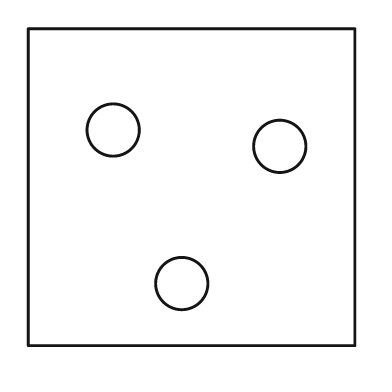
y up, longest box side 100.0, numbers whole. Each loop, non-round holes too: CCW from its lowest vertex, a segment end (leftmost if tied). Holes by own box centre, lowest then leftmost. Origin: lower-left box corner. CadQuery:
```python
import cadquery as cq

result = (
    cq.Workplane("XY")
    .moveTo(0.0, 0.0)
    .lineTo(100.0, 0.0)
    .lineTo(100.0, 97.0)
    .lineTo(0.0, 97.0)
    .close()
    .moveTo(47.0, 19.0)
    .circle(8.0)
    .moveTo(77.0, 61.0)
    .circle(8.0)
    .moveTo(26.0, 66.0)
    .circle(8.0)
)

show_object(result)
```